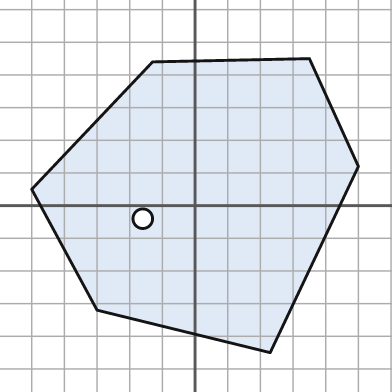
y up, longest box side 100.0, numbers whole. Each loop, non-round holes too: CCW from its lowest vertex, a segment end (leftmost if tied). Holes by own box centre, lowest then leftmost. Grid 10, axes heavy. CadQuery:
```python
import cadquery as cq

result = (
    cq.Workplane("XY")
    .moveTo(23.0, -45.0)
    .lineTo(50.0, 12.0)
    .lineTo(35.0, 45.0)
    .lineTo(-13.0, 44.0)
    .lineTo(-50.0, 5.0)
    .lineTo(-30.0, -32.0)
    .close()
    .moveTo(-16.0, -4.0)
    .circle(3.0)
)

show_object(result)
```